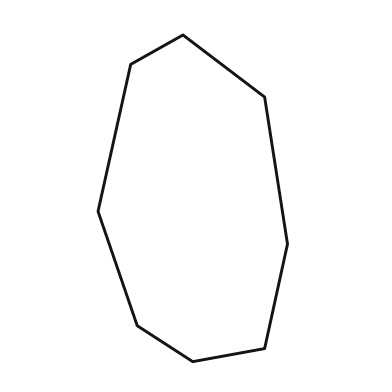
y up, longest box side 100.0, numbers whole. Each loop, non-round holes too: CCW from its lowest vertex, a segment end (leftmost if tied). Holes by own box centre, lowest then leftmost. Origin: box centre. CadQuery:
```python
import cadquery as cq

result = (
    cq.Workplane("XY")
    .moveTo(0.0, -50.0)
    .lineTo(22.0, -46.0)
    .lineTo(29.0, -14.0)
    .lineTo(22.0, 31.0)
    .lineTo(-3.0, 50.0)
    .lineTo(-19.0, 41.0)
    .lineTo(-29.0, -4.0)
    .lineTo(-17.0, -39.0)
    .close()
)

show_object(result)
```